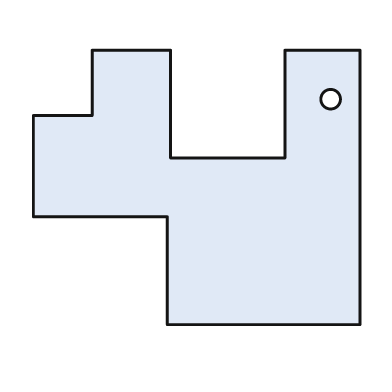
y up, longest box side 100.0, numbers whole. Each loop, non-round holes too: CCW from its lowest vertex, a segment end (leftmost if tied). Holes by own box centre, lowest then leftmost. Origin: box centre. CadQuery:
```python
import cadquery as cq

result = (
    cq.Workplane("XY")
    .moveTo(-9.0, -42.0)
    .lineTo(50.0, -42.0)
    .lineTo(50.0, 42.0)
    .lineTo(27.0, 42.0)
    .lineTo(27.0, 9.0)
    .lineTo(-8.0, 9.0)
    .lineTo(-8.0, 42.0)
    .lineTo(-32.0, 42.0)
    .lineTo(-32.0, 22.0)
    .lineTo(-50.0, 22.0)
    .lineTo(-50.0, -9.0)
    .lineTo(-9.0, -9.0)
    .close()
    .moveTo(41.0, 27.0)
    .circle(3.0)
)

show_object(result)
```